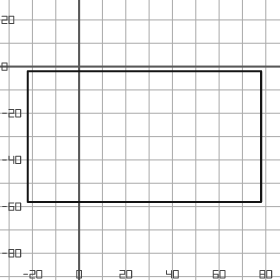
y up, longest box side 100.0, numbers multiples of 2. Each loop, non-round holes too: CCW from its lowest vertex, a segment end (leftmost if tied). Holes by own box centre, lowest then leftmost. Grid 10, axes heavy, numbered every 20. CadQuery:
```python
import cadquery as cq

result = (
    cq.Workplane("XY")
    .moveTo(-22.0, -58.0)
    .lineTo(78.0, -58.0)
    .lineTo(78.0, -2.0)
    .lineTo(-22.0, -2.0)
    .close()
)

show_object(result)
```